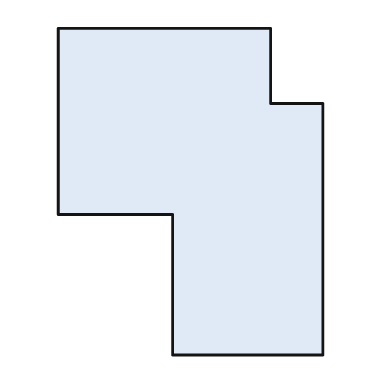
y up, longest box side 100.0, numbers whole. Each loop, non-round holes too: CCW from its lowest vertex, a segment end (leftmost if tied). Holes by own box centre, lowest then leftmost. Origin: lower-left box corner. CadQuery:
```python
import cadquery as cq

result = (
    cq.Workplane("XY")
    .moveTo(35.0, 0.0)
    .lineTo(81.0, 0.0)
    .lineTo(81.0, 77.0)
    .lineTo(65.0, 77.0)
    .lineTo(65.0, 100.0)
    .lineTo(0.0, 100.0)
    .lineTo(0.0, 43.0)
    .lineTo(35.0, 43.0)
    .close()
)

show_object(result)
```